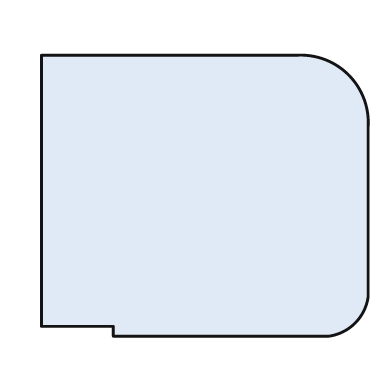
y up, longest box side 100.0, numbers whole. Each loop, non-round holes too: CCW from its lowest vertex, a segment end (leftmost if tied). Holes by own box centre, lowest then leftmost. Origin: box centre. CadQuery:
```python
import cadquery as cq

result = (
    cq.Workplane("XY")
    .moveTo(-28.0, -43.0)
    .lineTo(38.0, -43.0)
    .threePointArc((46.0, -39.0), (50.0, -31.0))
    .lineTo(50.0, 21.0)
    .threePointArc((44.0, 37.0), (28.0, 43.0))
    .lineTo(-50.0, 43.0)
    .lineTo(-50.0, -40.0)
    .lineTo(-28.0, -40.0)
    .close()
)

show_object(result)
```